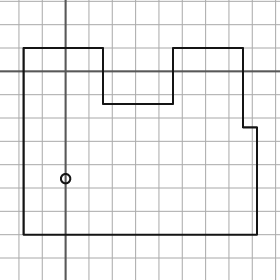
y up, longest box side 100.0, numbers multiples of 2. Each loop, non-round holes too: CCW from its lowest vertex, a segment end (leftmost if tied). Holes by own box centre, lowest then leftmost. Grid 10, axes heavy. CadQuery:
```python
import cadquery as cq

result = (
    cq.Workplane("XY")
    .moveTo(-18.0, -70.0)
    .lineTo(82.0, -70.0)
    .lineTo(82.0, -24.0)
    .lineTo(76.0, -24.0)
    .lineTo(76.0, 10.0)
    .lineTo(46.0, 10.0)
    .lineTo(46.0, -14.0)
    .lineTo(16.0, -14.0)
    .lineTo(16.0, 10.0)
    .lineTo(-18.0, 10.0)
    .close()
    .moveTo(0.0, -46.0)
    .circle(2.0)
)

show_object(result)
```